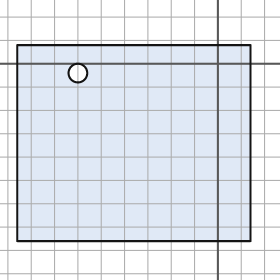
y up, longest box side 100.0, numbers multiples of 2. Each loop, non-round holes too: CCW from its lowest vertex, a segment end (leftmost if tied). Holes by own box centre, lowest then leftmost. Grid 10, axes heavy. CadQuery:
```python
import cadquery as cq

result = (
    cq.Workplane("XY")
    .moveTo(-86.0, -76.0)
    .lineTo(14.0, -76.0)
    .lineTo(14.0, 8.0)
    .lineTo(-86.0, 8.0)
    .close()
    .moveTo(-60.0, -4.0)
    .circle(4.0)
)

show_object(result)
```